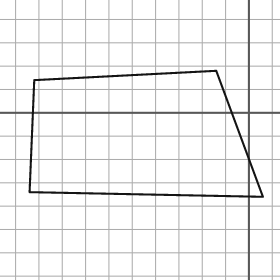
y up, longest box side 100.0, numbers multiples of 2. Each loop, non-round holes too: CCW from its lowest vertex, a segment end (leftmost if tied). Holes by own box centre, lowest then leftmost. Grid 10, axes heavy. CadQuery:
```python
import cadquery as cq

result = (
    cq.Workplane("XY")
    .moveTo(6.0, -36.0)
    .lineTo(-14.0, 18.0)
    .lineTo(-92.0, 14.0)
    .lineTo(-94.0, -34.0)
    .close()
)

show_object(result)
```